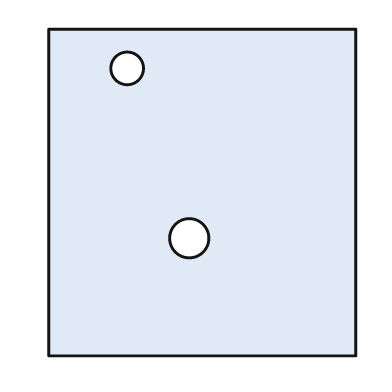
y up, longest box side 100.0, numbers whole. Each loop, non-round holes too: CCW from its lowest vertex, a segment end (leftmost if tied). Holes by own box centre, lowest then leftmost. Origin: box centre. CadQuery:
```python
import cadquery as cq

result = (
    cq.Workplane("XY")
    .moveTo(-47.0, -50.0)
    .lineTo(47.0, -50.0)
    .lineTo(47.0, 50.0)
    .lineTo(-47.0, 50.0)
    .close()
    .moveTo(-4.0, -14.0)
    .circle(6.0)
    .moveTo(-23.0, 38.0)
    .circle(5.0)
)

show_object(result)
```